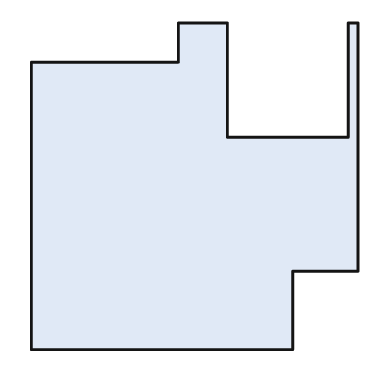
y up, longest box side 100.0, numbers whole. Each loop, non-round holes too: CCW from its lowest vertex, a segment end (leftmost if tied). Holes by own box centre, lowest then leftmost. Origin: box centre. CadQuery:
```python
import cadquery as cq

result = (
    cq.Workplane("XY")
    .moveTo(-50.0, -50.0)
    .lineTo(30.0, -50.0)
    .lineTo(30.0, -26.0)
    .lineTo(50.0, -26.0)
    .lineTo(50.0, 50.0)
    .lineTo(47.0, 50.0)
    .lineTo(47.0, 15.0)
    .lineTo(10.0, 15.0)
    .lineTo(10.0, 50.0)
    .lineTo(-5.0, 50.0)
    .lineTo(-5.0, 38.0)
    .lineTo(-50.0, 38.0)
    .close()
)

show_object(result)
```